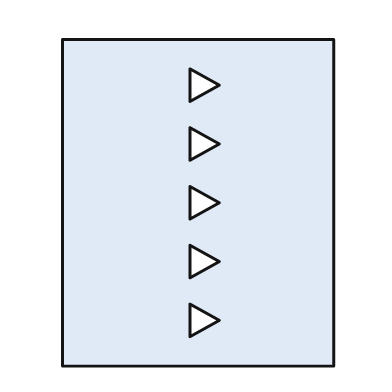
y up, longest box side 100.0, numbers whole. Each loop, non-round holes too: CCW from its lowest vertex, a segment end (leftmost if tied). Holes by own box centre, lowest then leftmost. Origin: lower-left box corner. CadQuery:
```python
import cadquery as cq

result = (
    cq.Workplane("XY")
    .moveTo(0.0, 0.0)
    .lineTo(83.0, 0.0)
    .lineTo(83.0, 100.0)
    .lineTo(0.0, 100.0)
    .close()
    .moveTo(39.0, 9.0)
    .lineTo(48.0, 14.0)
    .lineTo(39.0, 19.0)
    .close()
    .moveTo(39.0, 27.0)
    .lineTo(48.0, 32.0)
    .lineTo(39.0, 37.0)
    .close()
    .moveTo(39.0, 45.0)
    .lineTo(48.0, 50.0)
    .lineTo(39.0, 55.0)
    .close()
    .moveTo(39.0, 63.0)
    .lineTo(48.0, 68.0)
    .lineTo(39.0, 73.0)
    .close()
    .moveTo(39.0, 81.0)
    .lineTo(48.0, 86.0)
    .lineTo(39.0, 91.0)
    .close()
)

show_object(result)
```